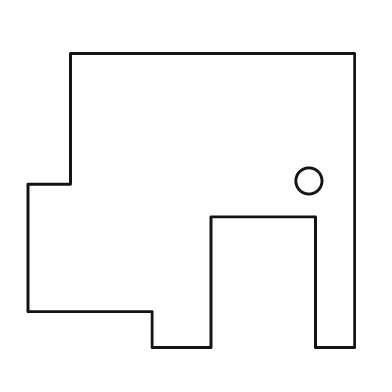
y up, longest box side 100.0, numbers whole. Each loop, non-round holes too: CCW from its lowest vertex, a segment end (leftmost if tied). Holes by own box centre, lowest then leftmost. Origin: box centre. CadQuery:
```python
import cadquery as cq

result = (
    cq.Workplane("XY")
    .moveTo(-12.0, -45.0)
    .lineTo(6.0, -45.0)
    .lineTo(6.0, -5.0)
    .lineTo(38.0, -5.0)
    .lineTo(38.0, -45.0)
    .lineTo(50.0, -45.0)
    .lineTo(50.0, 45.0)
    .lineTo(-37.0, 45.0)
    .lineTo(-37.0, 5.0)
    .lineTo(-50.0, 5.0)
    .lineTo(-50.0, -34.0)
    .lineTo(-12.0, -34.0)
    .close()
    .moveTo(36.0, 6.0)
    .circle(4.0)
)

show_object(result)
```